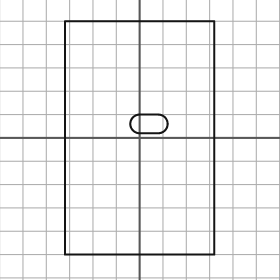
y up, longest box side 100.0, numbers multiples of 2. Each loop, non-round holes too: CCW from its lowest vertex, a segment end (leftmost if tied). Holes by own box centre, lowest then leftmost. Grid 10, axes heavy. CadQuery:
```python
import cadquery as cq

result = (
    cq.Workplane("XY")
    .moveTo(-32.0, -50.0)
    .lineTo(32.0, -50.0)
    .lineTo(32.0, 50.0)
    .lineTo(-32.0, 50.0)
    .close()
    .moveTo(0.0, 2.0)
    .lineTo(8.0, 2.0)
    .threePointArc((12.0, 6.0), (8.0, 10.0))
    .lineTo(0.0, 10.0)
    .threePointArc((-4.0, 6.0), (0.0, 2.0))
    .close()
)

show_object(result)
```